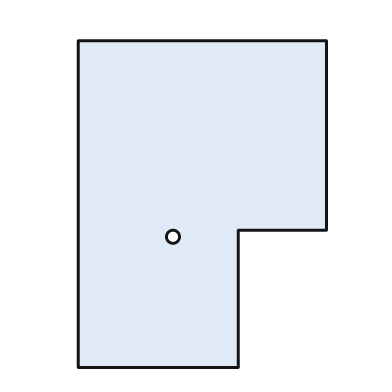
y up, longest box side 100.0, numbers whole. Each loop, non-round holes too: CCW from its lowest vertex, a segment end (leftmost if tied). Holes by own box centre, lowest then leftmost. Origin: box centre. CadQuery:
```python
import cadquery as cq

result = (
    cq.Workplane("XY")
    .moveTo(-38.0, -50.0)
    .lineTo(11.0, -50.0)
    .lineTo(11.0, -8.0)
    .lineTo(38.0, -8.0)
    .lineTo(38.0, 50.0)
    .lineTo(-38.0, 50.0)
    .close()
    .moveTo(-9.0, -10.0)
    .circle(2.0)
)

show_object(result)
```